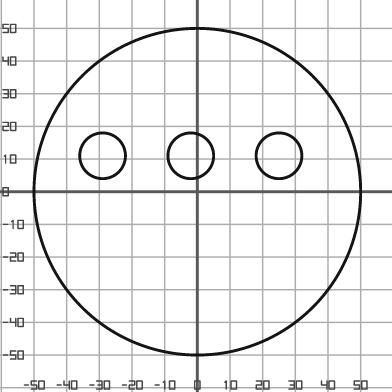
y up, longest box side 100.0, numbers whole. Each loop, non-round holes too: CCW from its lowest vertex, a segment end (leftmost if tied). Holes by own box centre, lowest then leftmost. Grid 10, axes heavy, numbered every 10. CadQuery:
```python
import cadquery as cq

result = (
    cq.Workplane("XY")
    .moveTo(0.0, 0.0)
    .circle(50.0)
    .moveTo(-29.0, 11.0)
    .circle(7.0)
    .moveTo(-2.0, 11.0)
    .circle(7.0)
    .moveTo(25.0, 11.0)
    .circle(7.0)
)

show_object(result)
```